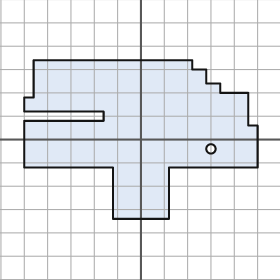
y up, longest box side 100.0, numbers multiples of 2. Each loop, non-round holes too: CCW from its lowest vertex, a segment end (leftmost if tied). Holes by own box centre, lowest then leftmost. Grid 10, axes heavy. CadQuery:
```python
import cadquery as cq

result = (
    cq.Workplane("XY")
    .moveTo(-12.0, -34.0)
    .lineTo(12.0, -34.0)
    .lineTo(12.0, -12.0)
    .lineTo(50.0, -12.0)
    .lineTo(50.0, 6.0)
    .lineTo(46.0, 6.0)
    .lineTo(46.0, 20.0)
    .lineTo(34.0, 20.0)
    .lineTo(34.0, 24.0)
    .lineTo(28.0, 24.0)
    .lineTo(28.0, 30.0)
    .lineTo(22.0, 30.0)
    .lineTo(22.0, 34.0)
    .lineTo(-46.0, 34.0)
    .lineTo(-46.0, 18.0)
    .lineTo(-50.0, 18.0)
    .lineTo(-50.0, 12.0)
    .lineTo(-16.0, 12.0)
    .lineTo(-16.0, 8.0)
    .lineTo(-50.0, 8.0)
    .lineTo(-50.0, -12.0)
    .lineTo(-12.0, -12.0)
    .close()
    .moveTo(30.0, -4.0)
    .circle(2.0)
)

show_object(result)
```